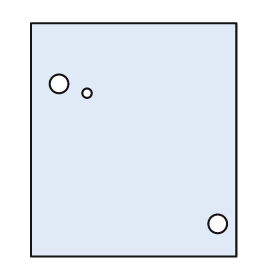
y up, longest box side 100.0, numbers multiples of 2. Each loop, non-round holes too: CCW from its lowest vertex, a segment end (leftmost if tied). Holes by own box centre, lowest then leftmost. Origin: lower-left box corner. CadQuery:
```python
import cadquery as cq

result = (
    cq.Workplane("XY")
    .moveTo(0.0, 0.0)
    .lineTo(88.0, 0.0)
    .lineTo(88.0, 100.0)
    .lineTo(0.0, 100.0)
    .close()
    .moveTo(80.0, 14.0)
    .circle(4.0)
    .moveTo(24.0, 70.0)
    .circle(2.0)
    .moveTo(12.0, 74.0)
    .circle(4.0)
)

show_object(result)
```